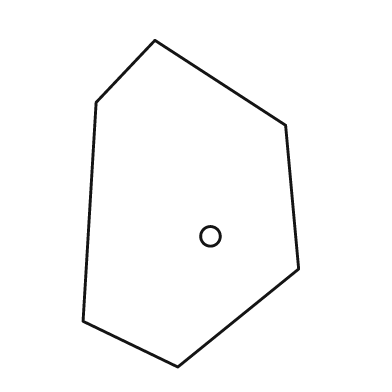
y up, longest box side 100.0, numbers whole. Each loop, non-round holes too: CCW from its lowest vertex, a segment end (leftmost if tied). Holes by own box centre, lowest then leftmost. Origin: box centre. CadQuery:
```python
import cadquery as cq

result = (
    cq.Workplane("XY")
    .moveTo(-4.0, -50.0)
    .lineTo(33.0, -20.0)
    .lineTo(29.0, 24.0)
    .lineTo(-11.0, 50.0)
    .lineTo(-29.0, 31.0)
    .lineTo(-33.0, -36.0)
    .close()
    .moveTo(6.0, -10.0)
    .circle(3.0)
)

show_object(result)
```